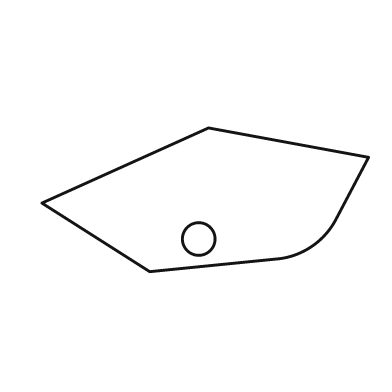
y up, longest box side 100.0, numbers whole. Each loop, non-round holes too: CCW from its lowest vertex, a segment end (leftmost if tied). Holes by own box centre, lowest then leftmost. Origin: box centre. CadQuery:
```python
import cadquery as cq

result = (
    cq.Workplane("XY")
    .moveTo(-17.0, -22.0)
    .lineTo(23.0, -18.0)
    .threePointArc((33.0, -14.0), (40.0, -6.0))
    .lineTo(50.0, 13.0)
    .lineTo(1.0, 22.0)
    .lineTo(-50.0, -1.0)
    .close()
    .moveTo(-2.0, -12.0)
    .circle(5.0)
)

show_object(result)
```